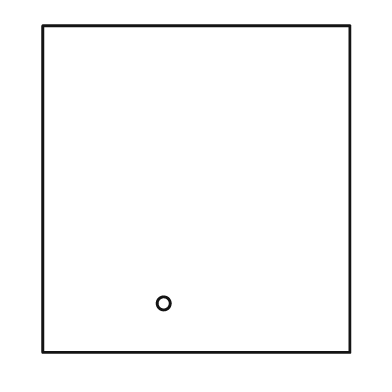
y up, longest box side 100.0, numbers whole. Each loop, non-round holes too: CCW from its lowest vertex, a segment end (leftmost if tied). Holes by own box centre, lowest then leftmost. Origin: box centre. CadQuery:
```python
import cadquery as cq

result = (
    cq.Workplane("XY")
    .moveTo(-47.0, -50.0)
    .lineTo(47.0, -50.0)
    .lineTo(47.0, 50.0)
    .lineTo(-47.0, 50.0)
    .close()
    .moveTo(-10.0, -35.0)
    .circle(2.0)
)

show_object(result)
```